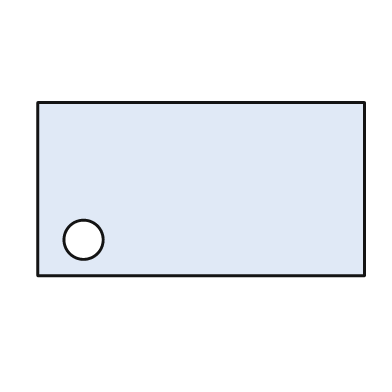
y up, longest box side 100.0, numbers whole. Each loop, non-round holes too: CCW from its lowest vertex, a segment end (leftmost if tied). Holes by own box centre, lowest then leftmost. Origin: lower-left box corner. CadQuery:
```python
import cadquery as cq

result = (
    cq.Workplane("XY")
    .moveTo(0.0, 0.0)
    .lineTo(100.0, 0.0)
    .lineTo(100.0, 53.0)
    .lineTo(0.0, 53.0)
    .close()
    .moveTo(14.0, 11.0)
    .circle(6.0)
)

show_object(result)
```